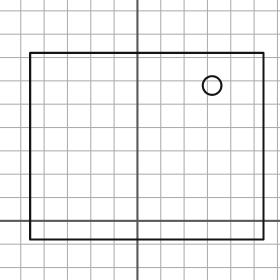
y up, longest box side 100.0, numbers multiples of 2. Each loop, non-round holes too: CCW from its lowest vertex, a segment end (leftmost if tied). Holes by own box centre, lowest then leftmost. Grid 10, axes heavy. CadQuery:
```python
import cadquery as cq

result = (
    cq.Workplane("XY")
    .moveTo(-46.0, -8.0)
    .lineTo(54.0, -8.0)
    .lineTo(54.0, 72.0)
    .lineTo(-46.0, 72.0)
    .close()
    .moveTo(32.0, 58.0)
    .circle(4.0)
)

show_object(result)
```